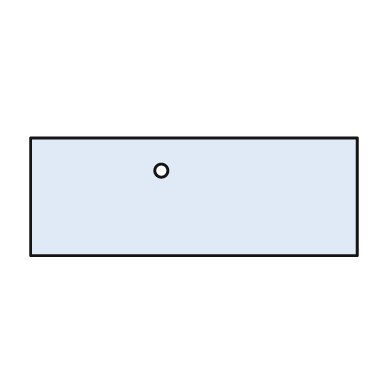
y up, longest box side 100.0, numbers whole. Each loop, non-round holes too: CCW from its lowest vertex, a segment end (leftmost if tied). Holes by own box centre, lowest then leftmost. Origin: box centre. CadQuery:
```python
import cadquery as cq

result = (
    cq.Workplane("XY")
    .moveTo(-50.0, -18.0)
    .lineTo(50.0, -18.0)
    .lineTo(50.0, 18.0)
    .lineTo(-50.0, 18.0)
    .close()
    .moveTo(-10.0, 8.0)
    .circle(2.0)
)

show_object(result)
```